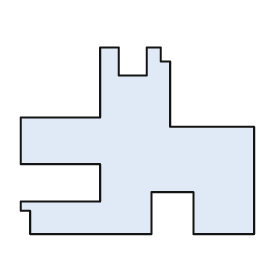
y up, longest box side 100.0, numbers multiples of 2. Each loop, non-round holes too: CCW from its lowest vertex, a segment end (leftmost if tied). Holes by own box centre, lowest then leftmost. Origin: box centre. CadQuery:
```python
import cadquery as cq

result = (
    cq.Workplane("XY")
    .moveTo(-46.0, -40.0)
    .lineTo(6.0, -40.0)
    .lineTo(6.0, -22.0)
    .lineTo(24.0, -22.0)
    .lineTo(24.0, -40.0)
    .lineTo(50.0, -40.0)
    .lineTo(50.0, 6.0)
    .lineTo(14.0, 6.0)
    .lineTo(14.0, 34.0)
    .lineTo(10.0, 34.0)
    .lineTo(10.0, 40.0)
    .lineTo(4.0, 40.0)
    .lineTo(4.0, 28.0)
    .lineTo(-8.0, 28.0)
    .lineTo(-8.0, 40.0)
    .lineTo(-16.0, 40.0)
    .lineTo(-16.0, 10.0)
    .lineTo(-50.0, 10.0)
    .lineTo(-50.0, -10.0)
    .lineTo(-16.0, -10.0)
    .lineTo(-16.0, -26.0)
    .lineTo(-50.0, -26.0)
    .lineTo(-50.0, -30.0)
    .lineTo(-46.0, -30.0)
    .close()
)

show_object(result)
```